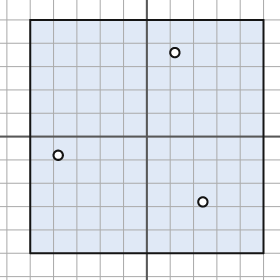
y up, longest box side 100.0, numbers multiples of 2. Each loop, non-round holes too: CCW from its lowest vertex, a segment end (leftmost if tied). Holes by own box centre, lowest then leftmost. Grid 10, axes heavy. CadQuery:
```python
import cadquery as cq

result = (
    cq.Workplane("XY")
    .moveTo(-50.0, -50.0)
    .lineTo(50.0, -50.0)
    .lineTo(50.0, 50.0)
    .lineTo(-50.0, 50.0)
    .close()
    .moveTo(24.0, -28.0)
    .circle(2.0)
    .moveTo(-38.0, -8.0)
    .circle(2.0)
    .moveTo(12.0, 36.0)
    .circle(2.0)
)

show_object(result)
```